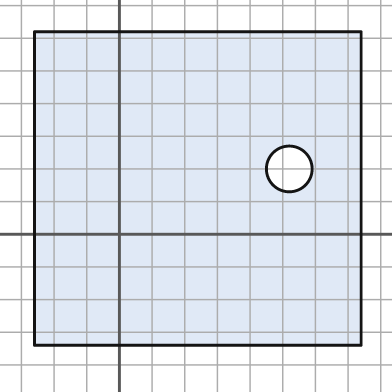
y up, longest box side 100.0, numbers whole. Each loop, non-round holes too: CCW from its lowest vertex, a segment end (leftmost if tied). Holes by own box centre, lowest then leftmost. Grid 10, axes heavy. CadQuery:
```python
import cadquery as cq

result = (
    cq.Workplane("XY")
    .moveTo(-26.0, -34.0)
    .lineTo(74.0, -34.0)
    .lineTo(74.0, 62.0)
    .lineTo(-26.0, 62.0)
    .close()
    .moveTo(52.0, 20.0)
    .circle(7.0)
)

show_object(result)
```